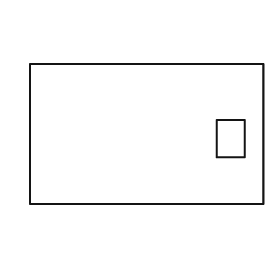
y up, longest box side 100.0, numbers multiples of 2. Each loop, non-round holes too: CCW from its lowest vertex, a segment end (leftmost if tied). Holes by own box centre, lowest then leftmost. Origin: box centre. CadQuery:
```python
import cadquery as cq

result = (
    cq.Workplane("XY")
    .moveTo(-50.0, -30.0)
    .lineTo(50.0, -30.0)
    .lineTo(50.0, 30.0)
    .lineTo(-50.0, 30.0)
    .close()
    .moveTo(30.0, -10.0)
    .lineTo(42.0, -10.0)
    .lineTo(42.0, 6.0)
    .lineTo(30.0, 6.0)
    .close()
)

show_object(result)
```